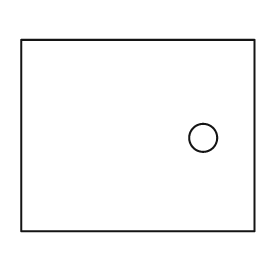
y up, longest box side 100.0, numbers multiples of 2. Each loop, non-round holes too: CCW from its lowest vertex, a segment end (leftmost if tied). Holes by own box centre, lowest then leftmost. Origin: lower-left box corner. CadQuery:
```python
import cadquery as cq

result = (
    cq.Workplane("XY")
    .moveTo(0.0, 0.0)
    .lineTo(100.0, 0.0)
    .lineTo(100.0, 82.0)
    .lineTo(0.0, 82.0)
    .close()
    .moveTo(78.0, 40.0)
    .circle(6.0)
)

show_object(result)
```